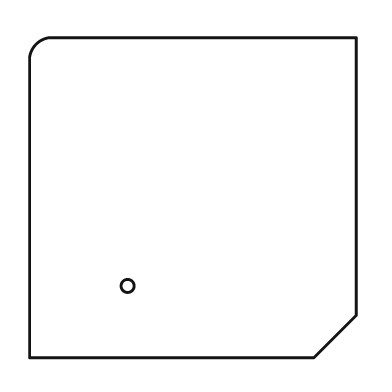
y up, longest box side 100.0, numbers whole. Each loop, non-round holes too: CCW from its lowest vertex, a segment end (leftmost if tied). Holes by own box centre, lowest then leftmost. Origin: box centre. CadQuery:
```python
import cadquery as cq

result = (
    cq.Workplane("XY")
    .moveTo(-50.0, -49.0)
    .lineTo(37.0, -49.0)
    .lineTo(50.0, -36.0)
    .lineTo(50.0, 49.0)
    .lineTo(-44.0, 49.0)
    .threePointArc((-48.0, 47.0), (-50.0, 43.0))
    .close()
    .moveTo(-20.0, -27.0)
    .circle(2.0)
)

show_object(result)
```